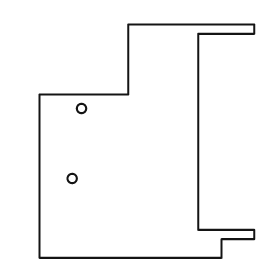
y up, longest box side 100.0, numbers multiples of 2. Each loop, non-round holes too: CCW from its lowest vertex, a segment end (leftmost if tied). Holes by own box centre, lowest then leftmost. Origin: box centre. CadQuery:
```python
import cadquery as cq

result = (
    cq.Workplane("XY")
    .moveTo(-46.0, -50.0)
    .lineTo(32.0, -50.0)
    .lineTo(32.0, -42.0)
    .lineTo(46.0, -42.0)
    .lineTo(46.0, -38.0)
    .lineTo(22.0, -38.0)
    .lineTo(22.0, 46.0)
    .lineTo(46.0, 46.0)
    .lineTo(46.0, 50.0)
    .lineTo(-8.0, 50.0)
    .lineTo(-8.0, 20.0)
    .lineTo(-46.0, 20.0)
    .close()
    .moveTo(-32.0, -16.0)
    .circle(2.0)
    .moveTo(-28.0, 14.0)
    .circle(2.0)
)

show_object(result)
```